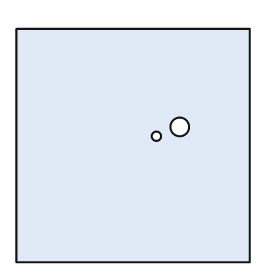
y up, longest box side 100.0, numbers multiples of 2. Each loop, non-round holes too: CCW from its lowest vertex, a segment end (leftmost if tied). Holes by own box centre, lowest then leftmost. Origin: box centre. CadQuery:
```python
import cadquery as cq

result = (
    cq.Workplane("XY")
    .moveTo(-50.0, -50.0)
    .lineTo(50.0, -50.0)
    .lineTo(50.0, 50.0)
    .lineTo(-50.0, 50.0)
    .close()
    .moveTo(10.0, 4.0)
    .circle(2.0)
    .moveTo(20.0, 8.0)
    .circle(4.0)
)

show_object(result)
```